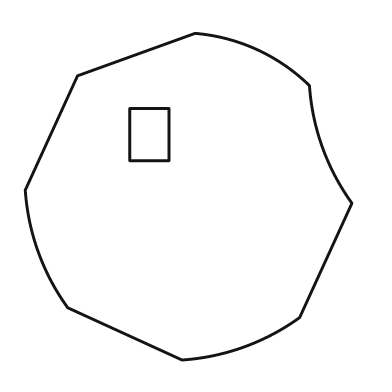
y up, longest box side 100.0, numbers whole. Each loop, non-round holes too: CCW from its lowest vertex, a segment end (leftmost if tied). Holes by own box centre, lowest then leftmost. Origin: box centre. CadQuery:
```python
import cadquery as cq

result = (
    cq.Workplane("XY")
    .moveTo(-2.0, -50.0)
    .threePointArc((17.0, -46.0), (34.0, -37.0))
    .lineTo(50.0, -2.0)
    .threePointArc((41.0, 15.0), (37.0, 34.0))
    .threePointArc((21.0, 45.0), (2.0, 50.0))
    .lineTo(-34.0, 37.0)
    .lineTo(-50.0, 2.0)
    .threePointArc((-46.0, -17.0), (-37.0, -34.0))
    .close()
    .moveTo(-18.0, 11.0)
    .lineTo(-6.0, 11.0)
    .lineTo(-6.0, 27.0)
    .lineTo(-18.0, 27.0)
    .close()
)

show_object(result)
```